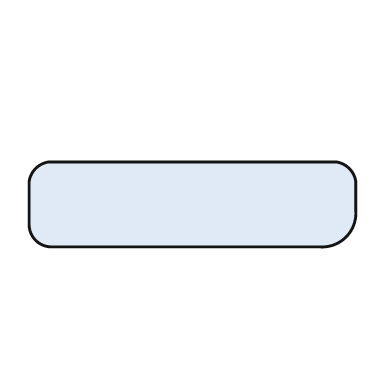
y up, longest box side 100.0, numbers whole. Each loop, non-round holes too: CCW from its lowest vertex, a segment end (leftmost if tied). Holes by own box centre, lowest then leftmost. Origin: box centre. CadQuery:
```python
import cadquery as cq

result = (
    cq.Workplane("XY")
    .moveTo(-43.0, -13.0)
    .lineTo(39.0, -13.0)
    .threePointArc((47.0, -10.0), (50.0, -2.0))
    .lineTo(50.0, 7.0)
    .threePointArc((48.0, 11.0), (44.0, 13.0))
    .lineTo(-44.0, 13.0)
    .threePointArc((-48.0, 11.0), (-50.0, 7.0))
    .lineTo(-50.0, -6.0)
    .threePointArc((-48.0, -11.0), (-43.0, -13.0))
    .close()
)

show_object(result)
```